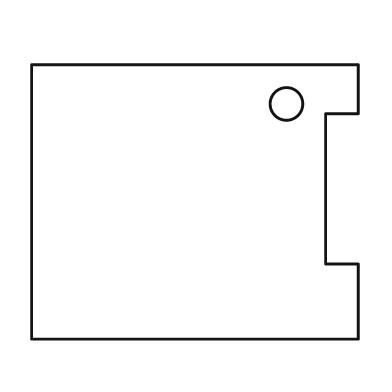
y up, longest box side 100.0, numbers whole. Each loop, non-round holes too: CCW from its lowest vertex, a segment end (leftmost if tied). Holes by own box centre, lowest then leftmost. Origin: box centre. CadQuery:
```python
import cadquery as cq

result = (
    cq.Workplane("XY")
    .moveTo(-50.0, -42.0)
    .lineTo(50.0, -42.0)
    .lineTo(50.0, -19.0)
    .lineTo(40.0, -19.0)
    .lineTo(40.0, 27.0)
    .lineTo(50.0, 27.0)
    .lineTo(50.0, 42.0)
    .lineTo(-50.0, 42.0)
    .close()
    .moveTo(28.0, 30.0)
    .circle(5.0)
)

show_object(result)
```